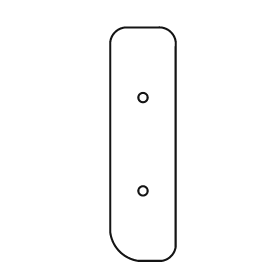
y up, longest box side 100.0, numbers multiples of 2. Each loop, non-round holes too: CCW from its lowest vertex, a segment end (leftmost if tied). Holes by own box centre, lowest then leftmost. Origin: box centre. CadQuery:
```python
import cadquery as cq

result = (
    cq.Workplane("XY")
    .moveTo(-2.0, -50.0)
    .lineTo(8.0, -50.0)
    .threePointArc((12.0, -48.0), (14.0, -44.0))
    .lineTo(14.0, 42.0)
    .threePointArc((12.0, 48.0), (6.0, 50.0))
    .lineTo(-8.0, 50.0)
    .threePointArc((-12.0, 48.0), (-14.0, 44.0))
    .lineTo(-14.0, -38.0)
    .threePointArc((-10.0, -46.0), (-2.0, -50.0))
    .close()
    .moveTo(0.0, -20.0)
    .circle(2.0)
    .moveTo(0.0, 20.0)
    .circle(2.0)
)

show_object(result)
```